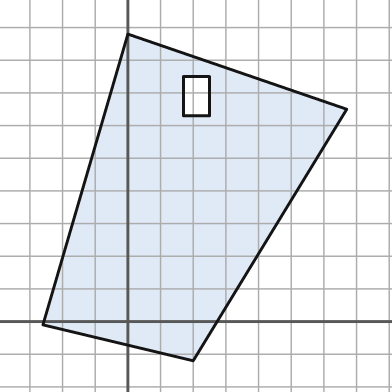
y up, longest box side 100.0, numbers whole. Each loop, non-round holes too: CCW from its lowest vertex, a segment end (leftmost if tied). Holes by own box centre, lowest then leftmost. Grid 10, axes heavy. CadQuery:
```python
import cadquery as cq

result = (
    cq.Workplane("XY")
    .moveTo(20.0, -12.0)
    .lineTo(67.0, 65.0)
    .lineTo(0.0, 88.0)
    .lineTo(-26.0, -1.0)
    .close()
    .moveTo(17.0, 63.0)
    .lineTo(25.0, 63.0)
    .lineTo(25.0, 75.0)
    .lineTo(17.0, 75.0)
    .close()
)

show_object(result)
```